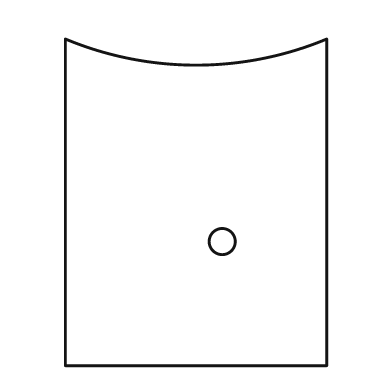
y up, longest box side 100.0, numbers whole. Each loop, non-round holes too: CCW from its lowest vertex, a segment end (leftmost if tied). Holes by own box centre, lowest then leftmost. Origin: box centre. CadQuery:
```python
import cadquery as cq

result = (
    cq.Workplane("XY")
    .moveTo(-40.0, -50.0)
    .lineTo(40.0, -50.0)
    .lineTo(40.0, 50.0)
    .threePointArc((0.0, 42.0), (-40.0, 50.0))
    .close()
    .moveTo(8.0, -12.0)
    .circle(4.0)
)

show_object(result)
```